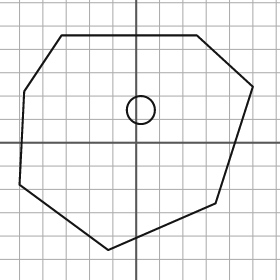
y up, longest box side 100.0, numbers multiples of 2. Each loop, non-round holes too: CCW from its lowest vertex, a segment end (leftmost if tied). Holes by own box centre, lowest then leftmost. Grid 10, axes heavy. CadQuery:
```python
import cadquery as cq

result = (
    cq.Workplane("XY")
    .moveTo(-12.0, -46.0)
    .lineTo(34.0, -26.0)
    .lineTo(50.0, 24.0)
    .lineTo(26.0, 46.0)
    .lineTo(-32.0, 46.0)
    .lineTo(-48.0, 22.0)
    .lineTo(-50.0, -18.0)
    .close()
    .moveTo(2.0, 14.0)
    .circle(6.0)
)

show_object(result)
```